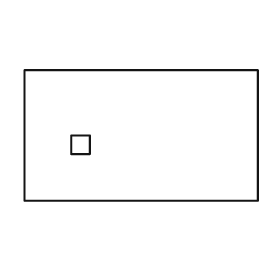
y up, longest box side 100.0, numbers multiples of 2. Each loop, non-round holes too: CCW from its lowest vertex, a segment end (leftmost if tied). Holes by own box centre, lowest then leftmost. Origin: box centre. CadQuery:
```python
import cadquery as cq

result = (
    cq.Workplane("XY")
    .moveTo(-50.0, -28.0)
    .lineTo(50.0, -28.0)
    .lineTo(50.0, 28.0)
    .lineTo(-50.0, 28.0)
    .close()
    .moveTo(-30.0, -8.0)
    .lineTo(-22.0, -8.0)
    .lineTo(-22.0, 0.0)
    .lineTo(-30.0, 0.0)
    .close()
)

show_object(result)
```